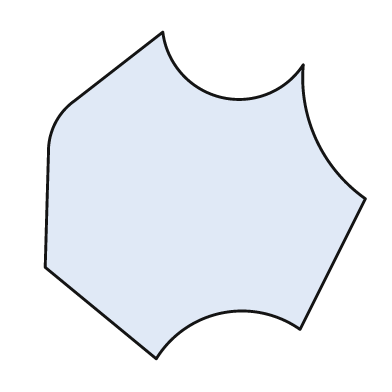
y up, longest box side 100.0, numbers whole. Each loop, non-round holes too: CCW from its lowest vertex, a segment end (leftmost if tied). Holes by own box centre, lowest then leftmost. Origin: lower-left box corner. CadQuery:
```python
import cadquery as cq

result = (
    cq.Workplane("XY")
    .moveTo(34.0, 0.0)
    .threePointArc((54.0, 14.0), (78.0, 9.0))
    .lineTo(98.0, 49.0)
    .threePointArc((83.0, 67.0), (79.0, 90.0))
    .threePointArc((54.0, 80.0), (36.0, 100.0))
    .lineTo(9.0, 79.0)
    .threePointArc((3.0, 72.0), (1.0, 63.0))
    .lineTo(0.0, 28.0)
    .close()
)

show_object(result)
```